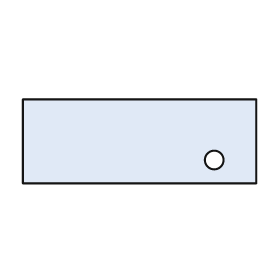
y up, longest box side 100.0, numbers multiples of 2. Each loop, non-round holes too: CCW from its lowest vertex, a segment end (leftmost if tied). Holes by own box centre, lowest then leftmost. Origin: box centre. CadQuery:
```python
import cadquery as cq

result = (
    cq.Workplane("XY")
    .moveTo(-50.0, -18.0)
    .lineTo(50.0, -18.0)
    .lineTo(50.0, 18.0)
    .lineTo(-50.0, 18.0)
    .close()
    .moveTo(32.0, -8.0)
    .circle(4.0)
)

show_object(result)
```